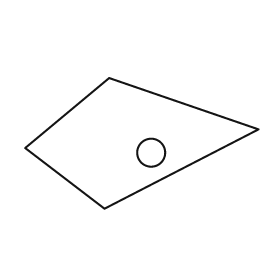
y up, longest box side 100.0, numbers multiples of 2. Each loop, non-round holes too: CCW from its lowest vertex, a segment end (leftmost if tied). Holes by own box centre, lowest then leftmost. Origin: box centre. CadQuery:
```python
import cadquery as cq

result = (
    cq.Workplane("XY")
    .moveTo(-16.0, -28.0)
    .lineTo(50.0, 6.0)
    .lineTo(-14.0, 28.0)
    .lineTo(-50.0, -2.0)
    .close()
    .moveTo(4.0, -4.0)
    .circle(6.0)
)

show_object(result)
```